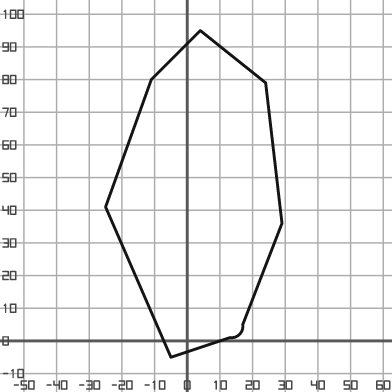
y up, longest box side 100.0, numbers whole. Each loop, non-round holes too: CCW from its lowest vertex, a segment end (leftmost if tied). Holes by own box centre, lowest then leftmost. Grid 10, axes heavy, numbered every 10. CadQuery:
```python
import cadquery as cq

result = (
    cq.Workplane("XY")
    .moveTo(-5.0, -5.0)
    .lineTo(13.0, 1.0)
    .threePointArc((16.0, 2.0), (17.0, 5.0))
    .lineTo(29.0, 36.0)
    .lineTo(24.0, 79.0)
    .lineTo(4.0, 95.0)
    .lineTo(-11.0, 80.0)
    .lineTo(-25.0, 41.0)
    .close()
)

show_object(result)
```